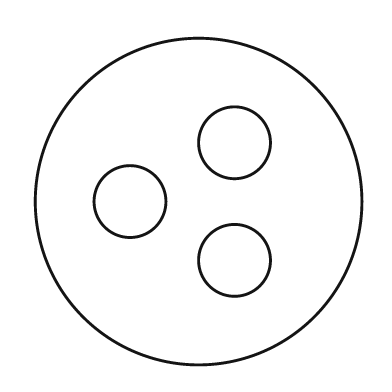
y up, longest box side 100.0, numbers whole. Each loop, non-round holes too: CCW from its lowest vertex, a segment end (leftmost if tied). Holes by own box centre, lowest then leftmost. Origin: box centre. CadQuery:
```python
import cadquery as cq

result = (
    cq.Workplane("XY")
    .moveTo(0.0, 0.0)
    .circle(50.0)
    .moveTo(11.0, -18.0)
    .circle(11.0)
    .moveTo(-21.0, 0.0)
    .circle(11.0)
    .moveTo(11.0, 18.0)
    .circle(11.0)
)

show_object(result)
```